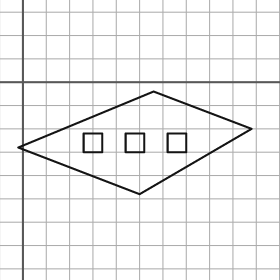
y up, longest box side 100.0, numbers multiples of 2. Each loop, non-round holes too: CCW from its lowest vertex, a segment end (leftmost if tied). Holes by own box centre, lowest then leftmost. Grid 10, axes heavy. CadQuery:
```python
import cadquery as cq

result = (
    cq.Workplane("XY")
    .moveTo(50.0, -48.0)
    .lineTo(98.0, -20.0)
    .lineTo(56.0, -4.0)
    .lineTo(-2.0, -28.0)
    .close()
    .moveTo(26.0, -30.0)
    .lineTo(34.0, -30.0)
    .lineTo(34.0, -22.0)
    .lineTo(26.0, -22.0)
    .close()
    .moveTo(44.0, -30.0)
    .lineTo(52.0, -30.0)
    .lineTo(52.0, -22.0)
    .lineTo(44.0, -22.0)
    .close()
    .moveTo(62.0, -30.0)
    .lineTo(70.0, -30.0)
    .lineTo(70.0, -22.0)
    .lineTo(62.0, -22.0)
    .close()
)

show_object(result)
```